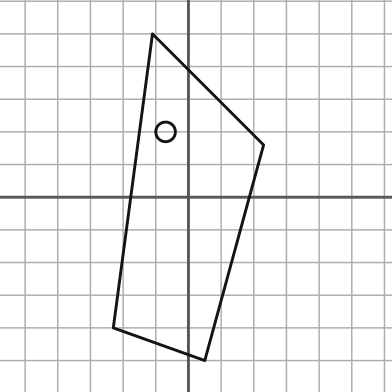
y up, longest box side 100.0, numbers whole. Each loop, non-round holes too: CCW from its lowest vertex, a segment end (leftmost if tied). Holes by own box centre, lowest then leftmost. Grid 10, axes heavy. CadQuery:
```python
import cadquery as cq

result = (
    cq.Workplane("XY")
    .moveTo(5.0, -50.0)
    .lineTo(23.0, 16.0)
    .lineTo(-11.0, 50.0)
    .lineTo(-23.0, -40.0)
    .close()
    .moveTo(-7.0, 20.0)
    .circle(3.0)
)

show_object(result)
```